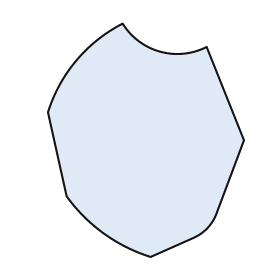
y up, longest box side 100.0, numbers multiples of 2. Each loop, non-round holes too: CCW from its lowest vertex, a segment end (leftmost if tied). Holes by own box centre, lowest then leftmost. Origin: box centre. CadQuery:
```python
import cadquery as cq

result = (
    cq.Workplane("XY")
    .moveTo(2.0, -50.0)
    .lineTo(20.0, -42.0)
    .threePointArc((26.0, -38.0), (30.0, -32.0))
    .lineTo(42.0, 0.0)
    .lineTo(26.0, 40.0)
    .threePointArc((6.0, 38.0), (-10.0, 50.0))
    .threePointArc((-30.0, 34.0), (-42.0, 12.0))
    .lineTo(-34.0, -24.0)
    .threePointArc((-18.0, -40.0), (2.0, -50.0))
    .close()
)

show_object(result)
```